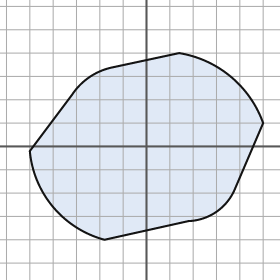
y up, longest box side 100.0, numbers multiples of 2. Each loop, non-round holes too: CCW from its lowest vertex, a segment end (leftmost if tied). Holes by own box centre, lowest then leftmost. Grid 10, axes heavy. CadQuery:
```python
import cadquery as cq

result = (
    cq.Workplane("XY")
    .moveTo(-18.0, -40.0)
    .lineTo(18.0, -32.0)
    .threePointArc((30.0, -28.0), (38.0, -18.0))
    .lineTo(50.0, 10.0)
    .threePointArc((36.0, 30.0), (14.0, 40.0))
    .lineTo(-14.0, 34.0)
    .threePointArc((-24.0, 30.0), (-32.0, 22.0))
    .lineTo(-50.0, -2.0)
    .threePointArc((-40.0, -26.0), (-18.0, -40.0))
    .close()
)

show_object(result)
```